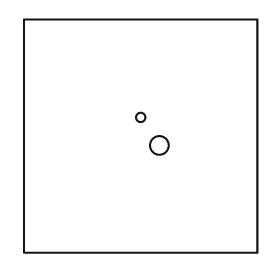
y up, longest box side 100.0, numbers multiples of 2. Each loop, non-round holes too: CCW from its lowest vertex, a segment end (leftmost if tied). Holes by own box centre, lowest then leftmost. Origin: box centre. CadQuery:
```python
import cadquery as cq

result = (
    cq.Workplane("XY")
    .moveTo(-50.0, -50.0)
    .lineTo(50.0, -50.0)
    .lineTo(50.0, 50.0)
    .lineTo(-50.0, 50.0)
    .close()
    .moveTo(8.0, -4.0)
    .circle(4.0)
    .moveTo(0.0, 8.0)
    .circle(2.0)
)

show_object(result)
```